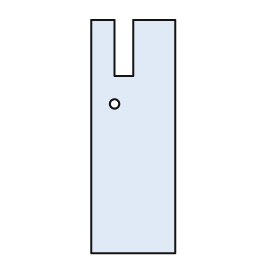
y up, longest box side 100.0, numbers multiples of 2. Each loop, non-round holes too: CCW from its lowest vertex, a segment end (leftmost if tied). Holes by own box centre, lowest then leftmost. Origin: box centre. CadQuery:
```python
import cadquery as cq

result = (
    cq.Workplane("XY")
    .moveTo(-18.0, -50.0)
    .lineTo(18.0, -50.0)
    .lineTo(18.0, 50.0)
    .lineTo(0.0, 50.0)
    .lineTo(0.0, 26.0)
    .lineTo(-8.0, 26.0)
    .lineTo(-8.0, 50.0)
    .lineTo(-18.0, 50.0)
    .close()
    .moveTo(-8.0, 14.0)
    .circle(2.0)
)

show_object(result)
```